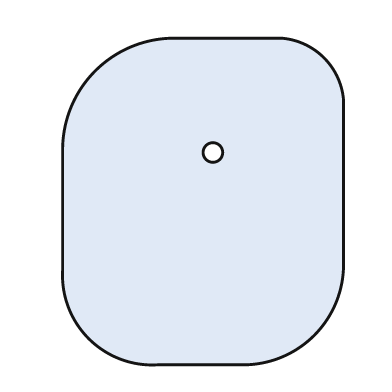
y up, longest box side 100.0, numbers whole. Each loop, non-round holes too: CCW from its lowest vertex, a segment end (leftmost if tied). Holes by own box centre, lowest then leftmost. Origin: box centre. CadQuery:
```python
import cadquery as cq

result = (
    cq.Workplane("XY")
    .moveTo(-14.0, -50.0)
    .lineTo(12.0, -50.0)
    .threePointArc((34.0, -41.0), (43.0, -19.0))
    .lineTo(43.0, 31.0)
    .threePointArc((37.0, 44.0), (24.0, 50.0))
    .lineTo(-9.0, 50.0)
    .threePointArc((-33.0, 40.0), (-43.0, 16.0))
    .lineTo(-43.0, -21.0)
    .threePointArc((-35.0, -42.0), (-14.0, -50.0))
    .close()
    .moveTo(3.0, 15.0)
    .circle(3.0)
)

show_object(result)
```